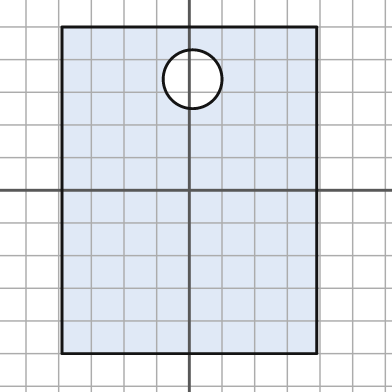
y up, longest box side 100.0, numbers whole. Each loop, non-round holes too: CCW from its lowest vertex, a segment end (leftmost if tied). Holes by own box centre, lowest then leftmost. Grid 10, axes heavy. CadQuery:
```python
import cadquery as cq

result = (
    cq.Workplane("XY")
    .moveTo(-39.0, -50.0)
    .lineTo(39.0, -50.0)
    .lineTo(39.0, 50.0)
    .lineTo(-39.0, 50.0)
    .close()
    .moveTo(1.0, 34.0)
    .circle(9.0)
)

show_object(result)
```